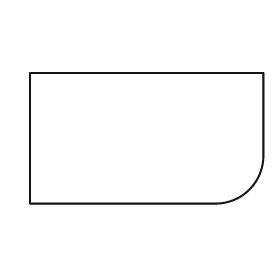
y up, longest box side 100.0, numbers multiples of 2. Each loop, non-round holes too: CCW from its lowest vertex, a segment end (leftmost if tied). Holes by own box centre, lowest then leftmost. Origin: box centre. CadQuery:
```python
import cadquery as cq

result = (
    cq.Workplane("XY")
    .moveTo(-50.0, -28.0)
    .lineTo(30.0, -28.0)
    .threePointArc((44.0, -22.0), (50.0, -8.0))
    .lineTo(50.0, 28.0)
    .lineTo(-50.0, 28.0)
    .close()
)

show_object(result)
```